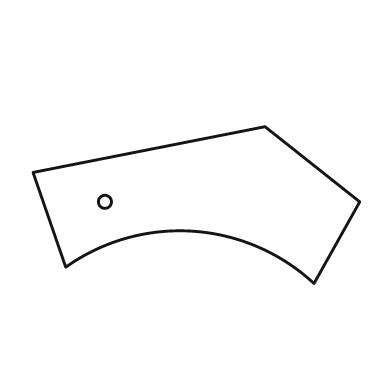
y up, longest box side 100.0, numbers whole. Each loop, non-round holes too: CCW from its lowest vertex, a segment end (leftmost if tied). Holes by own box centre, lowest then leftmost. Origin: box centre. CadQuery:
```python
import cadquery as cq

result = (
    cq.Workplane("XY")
    .moveTo(36.0, -24.0)
    .lineTo(50.0, 1.0)
    .lineTo(21.0, 24.0)
    .lineTo(-50.0, 10.0)
    .lineTo(-40.0, -19.0)
    .threePointArc((-1.0, -8.0), (36.0, -24.0))
    .close()
    .moveTo(-28.0, 1.0)
    .circle(2.0)
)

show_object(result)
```